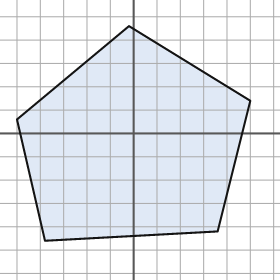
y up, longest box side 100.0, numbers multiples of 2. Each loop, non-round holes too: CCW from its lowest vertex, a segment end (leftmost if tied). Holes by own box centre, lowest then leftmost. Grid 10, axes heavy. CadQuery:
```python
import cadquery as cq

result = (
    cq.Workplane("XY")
    .moveTo(-38.0, -46.0)
    .lineTo(36.0, -42.0)
    .lineTo(50.0, 14.0)
    .lineTo(-2.0, 46.0)
    .lineTo(-50.0, 6.0)
    .close()
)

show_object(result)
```